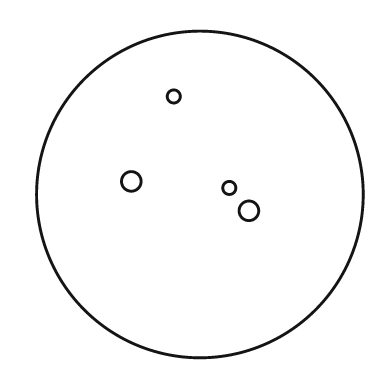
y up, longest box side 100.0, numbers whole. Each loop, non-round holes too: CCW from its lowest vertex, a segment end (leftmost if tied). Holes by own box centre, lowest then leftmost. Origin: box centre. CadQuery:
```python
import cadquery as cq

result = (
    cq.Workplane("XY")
    .moveTo(0.0, 0.0)
    .circle(50.0)
    .moveTo(15.0, -5.0)
    .circle(3.0)
    .moveTo(9.0, 2.0)
    .circle(2.0)
    .moveTo(-21.0, 4.0)
    .circle(3.0)
    .moveTo(-8.0, 30.0)
    .circle(2.0)
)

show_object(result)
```